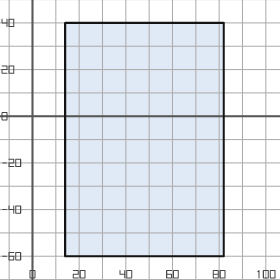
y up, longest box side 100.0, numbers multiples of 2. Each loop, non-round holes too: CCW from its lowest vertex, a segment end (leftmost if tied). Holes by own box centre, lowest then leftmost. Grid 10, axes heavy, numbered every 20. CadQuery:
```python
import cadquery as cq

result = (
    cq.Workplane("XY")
    .moveTo(14.0, -60.0)
    .lineTo(82.0, -60.0)
    .lineTo(82.0, 40.0)
    .lineTo(14.0, 40.0)
    .close()
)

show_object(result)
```